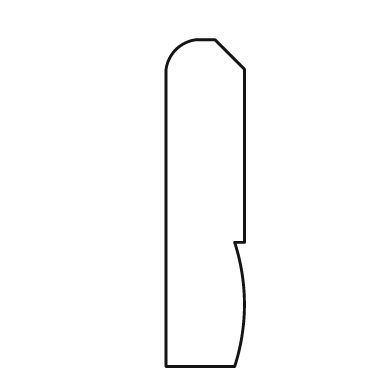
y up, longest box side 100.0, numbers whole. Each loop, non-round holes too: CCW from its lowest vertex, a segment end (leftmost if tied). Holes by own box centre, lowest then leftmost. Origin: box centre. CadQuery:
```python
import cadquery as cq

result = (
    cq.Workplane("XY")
    .moveTo(-12.0, -50.0)
    .lineTo(9.0, -50.0)
    .threePointArc((12.0, -31.0), (9.0, -12.0))
    .lineTo(12.0, -12.0)
    .lineTo(12.0, 41.0)
    .lineTo(3.0, 50.0)
    .lineTo(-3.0, 50.0)
    .threePointArc((-9.0, 47.0), (-12.0, 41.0))
    .close()
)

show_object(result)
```